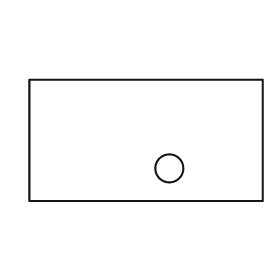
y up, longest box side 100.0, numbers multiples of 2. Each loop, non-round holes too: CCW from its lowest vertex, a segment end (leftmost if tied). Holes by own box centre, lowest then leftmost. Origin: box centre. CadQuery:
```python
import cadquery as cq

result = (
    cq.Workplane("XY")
    .moveTo(-50.0, -26.0)
    .lineTo(50.0, -26.0)
    .lineTo(50.0, 26.0)
    .lineTo(-50.0, 26.0)
    .close()
    .moveTo(10.0, -12.0)
    .circle(6.0)
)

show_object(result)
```